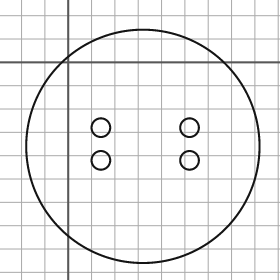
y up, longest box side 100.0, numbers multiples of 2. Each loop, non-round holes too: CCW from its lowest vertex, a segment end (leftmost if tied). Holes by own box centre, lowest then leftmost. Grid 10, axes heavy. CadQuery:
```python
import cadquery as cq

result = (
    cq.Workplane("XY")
    .moveTo(32.0, -36.0)
    .circle(50.0)
    .moveTo(14.0, -42.0)
    .circle(4.0)
    .moveTo(52.0, -42.0)
    .circle(4.0)
    .moveTo(14.0, -28.0)
    .circle(4.0)
    .moveTo(52.0, -28.0)
    .circle(4.0)
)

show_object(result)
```